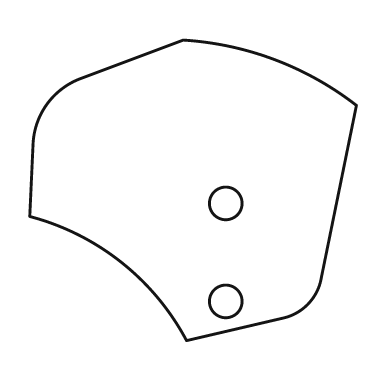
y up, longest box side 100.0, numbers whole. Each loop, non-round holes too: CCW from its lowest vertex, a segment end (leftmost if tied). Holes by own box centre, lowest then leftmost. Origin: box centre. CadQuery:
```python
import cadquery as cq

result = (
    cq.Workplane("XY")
    .moveTo(-2.0, -46.0)
    .lineTo(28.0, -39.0)
    .threePointArc((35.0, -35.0), (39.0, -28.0))
    .lineTo(50.0, 26.0)
    .threePointArc((25.0, 40.0), (-3.0, 46.0))
    .lineTo(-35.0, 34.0)
    .threePointArc((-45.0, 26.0), (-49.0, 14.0))
    .lineTo(-50.0, -8.0)
    .threePointArc((-22.0, -22.0), (-2.0, -46.0))
    .close()
    .moveTo(10.0, -34.0)
    .circle(5.0)
    .moveTo(10.0, -4.0)
    .circle(5.0)
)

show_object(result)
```